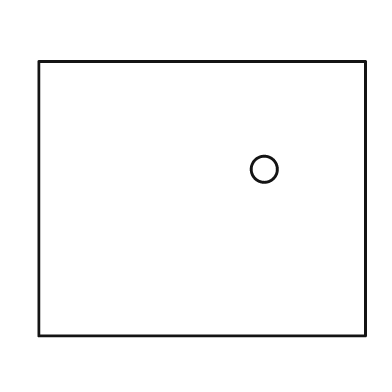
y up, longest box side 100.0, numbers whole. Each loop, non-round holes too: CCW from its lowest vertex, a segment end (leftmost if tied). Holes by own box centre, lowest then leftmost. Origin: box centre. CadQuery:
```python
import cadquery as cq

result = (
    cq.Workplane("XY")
    .moveTo(-50.0, -42.0)
    .lineTo(50.0, -42.0)
    .lineTo(50.0, 42.0)
    .lineTo(-50.0, 42.0)
    .close()
    .moveTo(19.0, 9.0)
    .circle(4.0)
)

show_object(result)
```